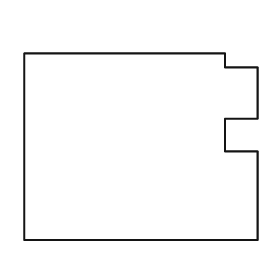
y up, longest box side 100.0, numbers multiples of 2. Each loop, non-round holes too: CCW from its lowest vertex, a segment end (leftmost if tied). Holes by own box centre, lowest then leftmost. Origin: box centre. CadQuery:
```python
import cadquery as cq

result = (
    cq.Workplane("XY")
    .moveTo(-50.0, -40.0)
    .lineTo(50.0, -40.0)
    .lineTo(50.0, -2.0)
    .lineTo(36.0, -2.0)
    .lineTo(36.0, 12.0)
    .lineTo(50.0, 12.0)
    .lineTo(50.0, 34.0)
    .lineTo(36.0, 34.0)
    .lineTo(36.0, 40.0)
    .lineTo(-50.0, 40.0)
    .close()
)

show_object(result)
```